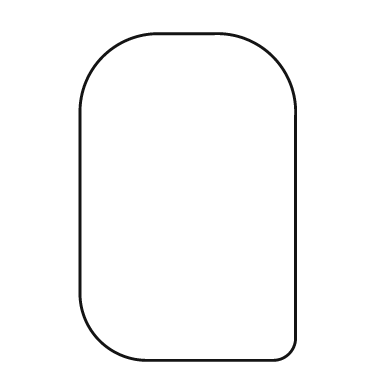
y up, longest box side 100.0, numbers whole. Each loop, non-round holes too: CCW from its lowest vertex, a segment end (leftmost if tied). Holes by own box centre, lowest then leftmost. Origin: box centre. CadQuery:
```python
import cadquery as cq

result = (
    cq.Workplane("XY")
    .moveTo(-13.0, -50.0)
    .lineTo(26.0, -50.0)
    .threePointArc((31.0, -48.0), (33.0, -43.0))
    .lineTo(33.0, 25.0)
    .threePointArc((26.0, 43.0), (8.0, 50.0))
    .lineTo(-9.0, 50.0)
    .threePointArc((-26.0, 43.0), (-33.0, 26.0))
    .lineTo(-33.0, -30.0)
    .threePointArc((-27.0, -44.0), (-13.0, -50.0))
    .close()
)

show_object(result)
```